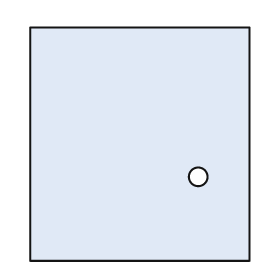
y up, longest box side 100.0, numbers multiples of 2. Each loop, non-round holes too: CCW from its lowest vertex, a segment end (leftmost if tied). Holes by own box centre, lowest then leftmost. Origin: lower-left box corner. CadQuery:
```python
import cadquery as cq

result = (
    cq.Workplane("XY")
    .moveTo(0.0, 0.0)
    .lineTo(94.0, 0.0)
    .lineTo(94.0, 100.0)
    .lineTo(0.0, 100.0)
    .close()
    .moveTo(72.0, 36.0)
    .circle(4.0)
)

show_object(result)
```